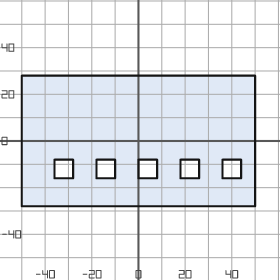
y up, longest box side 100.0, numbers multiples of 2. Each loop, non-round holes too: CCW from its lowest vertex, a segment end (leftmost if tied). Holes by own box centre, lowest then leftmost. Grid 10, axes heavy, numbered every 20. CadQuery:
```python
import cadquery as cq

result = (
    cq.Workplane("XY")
    .moveTo(-50.0, -28.0)
    .lineTo(50.0, -28.0)
    .lineTo(50.0, 28.0)
    .lineTo(-50.0, 28.0)
    .close()
    .moveTo(-36.0, -16.0)
    .lineTo(-28.0, -16.0)
    .lineTo(-28.0, -8.0)
    .lineTo(-36.0, -8.0)
    .close()
    .moveTo(-18.0, -16.0)
    .lineTo(-10.0, -16.0)
    .lineTo(-10.0, -8.0)
    .lineTo(-18.0, -8.0)
    .close()
    .moveTo(0.0, -16.0)
    .lineTo(8.0, -16.0)
    .lineTo(8.0, -8.0)
    .lineTo(0.0, -8.0)
    .close()
    .moveTo(18.0, -16.0)
    .lineTo(26.0, -16.0)
    .lineTo(26.0, -8.0)
    .lineTo(18.0, -8.0)
    .close()
    .moveTo(36.0, -16.0)
    .lineTo(44.0, -16.0)
    .lineTo(44.0, -8.0)
    .lineTo(36.0, -8.0)
    .close()
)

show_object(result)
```